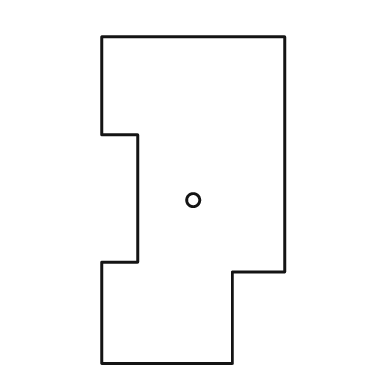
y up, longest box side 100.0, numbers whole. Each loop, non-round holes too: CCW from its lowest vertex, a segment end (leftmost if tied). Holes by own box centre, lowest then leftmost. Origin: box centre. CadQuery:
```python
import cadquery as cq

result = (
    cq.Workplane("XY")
    .moveTo(-28.0, -50.0)
    .lineTo(12.0, -50.0)
    .lineTo(12.0, -22.0)
    .lineTo(28.0, -22.0)
    .lineTo(28.0, 50.0)
    .lineTo(-28.0, 50.0)
    .lineTo(-28.0, 20.0)
    .lineTo(-17.0, 20.0)
    .lineTo(-17.0, -19.0)
    .lineTo(-28.0, -19.0)
    .close()
    .moveTo(0.0, 0.0)
    .circle(2.0)
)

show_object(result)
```